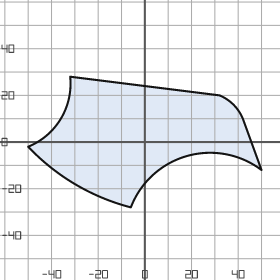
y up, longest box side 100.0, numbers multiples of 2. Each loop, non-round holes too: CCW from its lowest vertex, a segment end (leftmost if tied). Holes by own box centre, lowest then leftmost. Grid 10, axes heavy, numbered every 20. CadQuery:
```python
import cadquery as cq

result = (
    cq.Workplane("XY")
    .moveTo(-6.0, -28.0)
    .threePointArc((18.0, -6.0), (50.0, -12.0))
    .lineTo(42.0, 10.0)
    .threePointArc((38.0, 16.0), (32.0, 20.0))
    .lineTo(-32.0, 28.0)
    .threePointArc((-36.0, 10.0), (-50.0, -2.0))
    .threePointArc((-30.0, -18.0), (-6.0, -28.0))
    .close()
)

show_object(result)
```